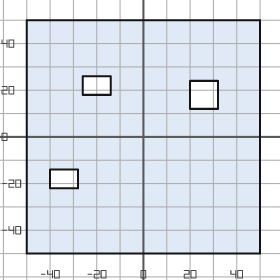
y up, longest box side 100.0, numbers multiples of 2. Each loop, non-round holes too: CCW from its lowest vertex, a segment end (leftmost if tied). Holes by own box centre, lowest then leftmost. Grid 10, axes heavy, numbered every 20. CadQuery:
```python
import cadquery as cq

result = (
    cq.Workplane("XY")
    .moveTo(-50.0, -50.0)
    .lineTo(50.0, -50.0)
    .lineTo(50.0, 50.0)
    .lineTo(-50.0, 50.0)
    .close()
    .moveTo(-40.0, -22.0)
    .lineTo(-28.0, -22.0)
    .lineTo(-28.0, -14.0)
    .lineTo(-40.0, -14.0)
    .close()
    .moveTo(20.0, 12.0)
    .lineTo(32.0, 12.0)
    .lineTo(32.0, 24.0)
    .lineTo(20.0, 24.0)
    .close()
    .moveTo(-26.0, 18.0)
    .lineTo(-14.0, 18.0)
    .lineTo(-14.0, 26.0)
    .lineTo(-26.0, 26.0)
    .close()
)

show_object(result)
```